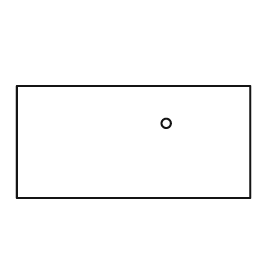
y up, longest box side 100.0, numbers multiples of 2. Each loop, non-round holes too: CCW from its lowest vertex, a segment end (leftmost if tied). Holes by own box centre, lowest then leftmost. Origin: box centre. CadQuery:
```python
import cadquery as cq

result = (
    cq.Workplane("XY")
    .moveTo(-50.0, -24.0)
    .lineTo(50.0, -24.0)
    .lineTo(50.0, 24.0)
    .lineTo(-50.0, 24.0)
    .close()
    .moveTo(14.0, 8.0)
    .circle(2.0)
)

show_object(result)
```